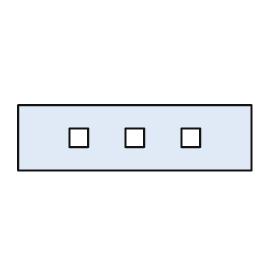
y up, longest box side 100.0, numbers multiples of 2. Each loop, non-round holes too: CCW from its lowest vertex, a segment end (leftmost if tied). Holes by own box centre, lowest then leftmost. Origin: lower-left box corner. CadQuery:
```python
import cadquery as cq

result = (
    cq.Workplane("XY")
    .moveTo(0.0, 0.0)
    .lineTo(100.0, 0.0)
    .lineTo(100.0, 28.0)
    .lineTo(0.0, 28.0)
    .close()
    .moveTo(22.0, 10.0)
    .lineTo(30.0, 10.0)
    .lineTo(30.0, 18.0)
    .lineTo(22.0, 18.0)
    .close()
    .moveTo(46.0, 10.0)
    .lineTo(54.0, 10.0)
    .lineTo(54.0, 18.0)
    .lineTo(46.0, 18.0)
    .close()
    .moveTo(70.0, 10.0)
    .lineTo(78.0, 10.0)
    .lineTo(78.0, 18.0)
    .lineTo(70.0, 18.0)
    .close()
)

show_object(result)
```